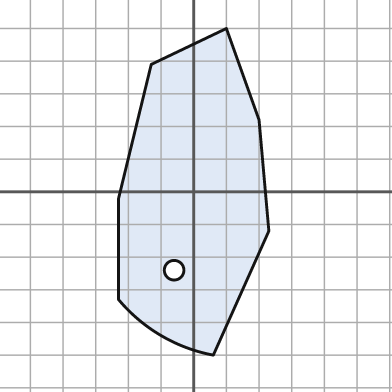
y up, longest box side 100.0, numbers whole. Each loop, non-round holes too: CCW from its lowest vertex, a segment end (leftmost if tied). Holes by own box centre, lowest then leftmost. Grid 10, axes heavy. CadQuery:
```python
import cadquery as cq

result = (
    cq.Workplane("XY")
    .moveTo(6.0, -50.0)
    .lineTo(23.0, -12.0)
    .lineTo(20.0, 22.0)
    .lineTo(10.0, 50.0)
    .lineTo(-13.0, 39.0)
    .lineTo(-23.0, -2.0)
    .lineTo(-23.0, -33.0)
    .threePointArc((-10.0, -44.0), (6.0, -50.0))
    .close()
    .moveTo(-6.0, -24.0)
    .circle(3.0)
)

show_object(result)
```